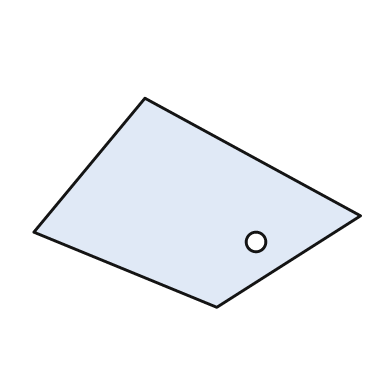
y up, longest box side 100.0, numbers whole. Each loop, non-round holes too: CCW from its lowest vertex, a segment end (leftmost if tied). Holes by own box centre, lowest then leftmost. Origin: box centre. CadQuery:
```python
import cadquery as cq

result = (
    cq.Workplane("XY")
    .moveTo(6.0, -32.0)
    .lineTo(50.0, -4.0)
    .lineTo(-16.0, 32.0)
    .lineTo(-50.0, -9.0)
    .close()
    .moveTo(18.0, -12.0)
    .circle(3.0)
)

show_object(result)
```